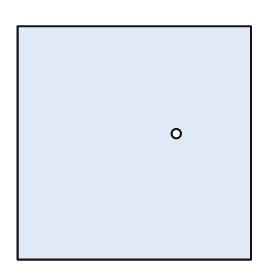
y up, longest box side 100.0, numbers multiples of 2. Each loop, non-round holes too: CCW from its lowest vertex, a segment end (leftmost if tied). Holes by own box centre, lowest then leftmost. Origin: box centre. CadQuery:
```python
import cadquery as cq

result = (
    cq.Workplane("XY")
    .moveTo(-50.0, -50.0)
    .lineTo(50.0, -50.0)
    .lineTo(50.0, 50.0)
    .lineTo(-50.0, 50.0)
    .close()
    .moveTo(18.0, 4.0)
    .circle(2.0)
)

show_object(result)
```